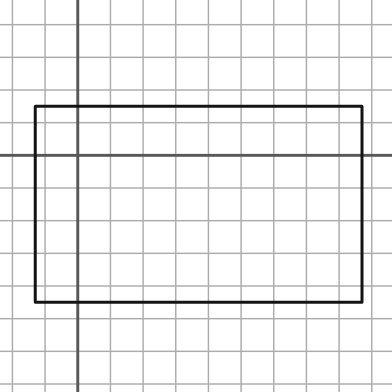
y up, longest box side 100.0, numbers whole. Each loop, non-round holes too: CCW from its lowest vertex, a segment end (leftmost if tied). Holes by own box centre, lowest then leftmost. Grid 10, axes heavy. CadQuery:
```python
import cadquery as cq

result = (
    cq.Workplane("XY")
    .moveTo(-13.0, -45.0)
    .lineTo(87.0, -45.0)
    .lineTo(87.0, 15.0)
    .lineTo(-13.0, 15.0)
    .close()
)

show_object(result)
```